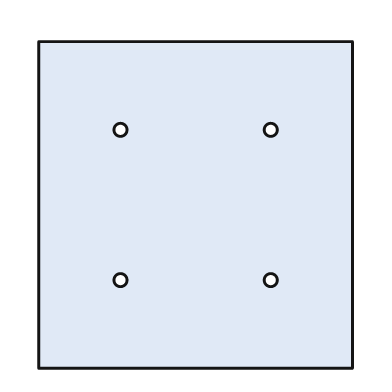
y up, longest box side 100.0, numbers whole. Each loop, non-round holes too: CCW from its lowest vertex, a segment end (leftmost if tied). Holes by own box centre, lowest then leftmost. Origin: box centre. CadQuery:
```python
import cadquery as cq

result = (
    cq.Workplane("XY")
    .moveTo(-48.0, -50.0)
    .lineTo(48.0, -50.0)
    .lineTo(48.0, 50.0)
    .lineTo(-48.0, 50.0)
    .close()
    .moveTo(-23.0, -23.0)
    .circle(2.0)
    .moveTo(23.0, -23.0)
    .circle(2.0)
    .moveTo(-23.0, 23.0)
    .circle(2.0)
    .moveTo(23.0, 23.0)
    .circle(2.0)
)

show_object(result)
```